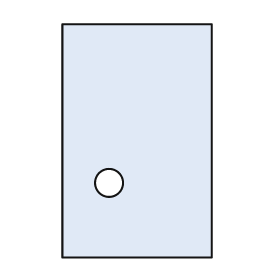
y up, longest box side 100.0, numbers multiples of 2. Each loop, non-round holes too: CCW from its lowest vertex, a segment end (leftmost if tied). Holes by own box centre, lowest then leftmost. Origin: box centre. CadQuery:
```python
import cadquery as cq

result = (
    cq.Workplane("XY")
    .moveTo(-32.0, -50.0)
    .lineTo(32.0, -50.0)
    .lineTo(32.0, 50.0)
    .lineTo(-32.0, 50.0)
    .close()
    .moveTo(-12.0, -18.0)
    .circle(6.0)
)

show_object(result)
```